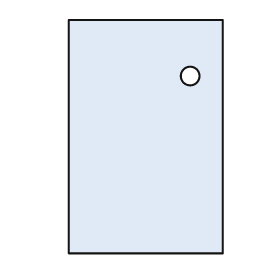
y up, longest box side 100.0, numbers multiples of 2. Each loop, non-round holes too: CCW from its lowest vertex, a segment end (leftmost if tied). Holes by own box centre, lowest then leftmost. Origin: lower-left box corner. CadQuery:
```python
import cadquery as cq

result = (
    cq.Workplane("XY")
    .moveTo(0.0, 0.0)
    .lineTo(66.0, 0.0)
    .lineTo(66.0, 100.0)
    .lineTo(0.0, 100.0)
    .close()
    .moveTo(52.0, 76.0)
    .circle(4.0)
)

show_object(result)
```